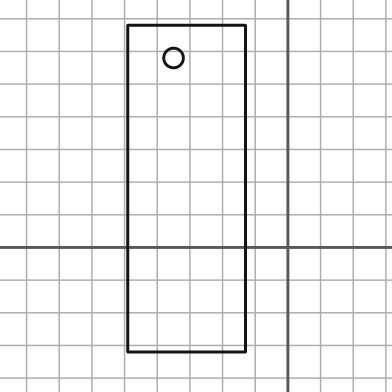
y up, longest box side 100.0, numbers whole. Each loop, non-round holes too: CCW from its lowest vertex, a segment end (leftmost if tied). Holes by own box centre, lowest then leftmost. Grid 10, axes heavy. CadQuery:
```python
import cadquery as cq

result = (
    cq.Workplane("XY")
    .moveTo(-49.0, -32.0)
    .lineTo(-13.0, -32.0)
    .lineTo(-13.0, 68.0)
    .lineTo(-49.0, 68.0)
    .close()
    .moveTo(-35.0, 58.0)
    .circle(3.0)
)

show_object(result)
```